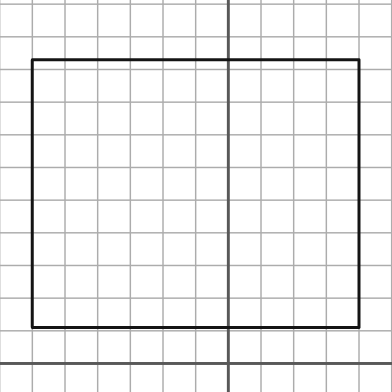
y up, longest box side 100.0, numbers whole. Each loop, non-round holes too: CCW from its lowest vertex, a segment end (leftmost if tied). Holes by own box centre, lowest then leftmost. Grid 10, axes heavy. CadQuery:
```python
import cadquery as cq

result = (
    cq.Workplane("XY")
    .moveTo(-60.0, 11.0)
    .lineTo(40.0, 11.0)
    .lineTo(40.0, 93.0)
    .lineTo(-60.0, 93.0)
    .close()
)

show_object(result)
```